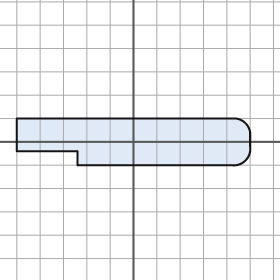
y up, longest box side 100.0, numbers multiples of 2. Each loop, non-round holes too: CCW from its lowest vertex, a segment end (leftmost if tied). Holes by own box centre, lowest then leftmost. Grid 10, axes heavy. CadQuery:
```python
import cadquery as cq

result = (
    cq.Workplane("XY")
    .moveTo(-24.0, -10.0)
    .lineTo(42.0, -10.0)
    .threePointArc((48.0, -8.0), (50.0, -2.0))
    .lineTo(50.0, 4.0)
    .threePointArc((48.0, 8.0), (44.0, 10.0))
    .lineTo(-50.0, 10.0)
    .lineTo(-50.0, -4.0)
    .lineTo(-24.0, -4.0)
    .close()
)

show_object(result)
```